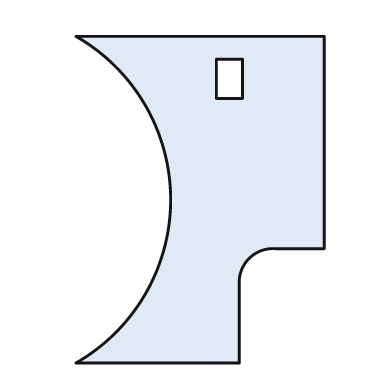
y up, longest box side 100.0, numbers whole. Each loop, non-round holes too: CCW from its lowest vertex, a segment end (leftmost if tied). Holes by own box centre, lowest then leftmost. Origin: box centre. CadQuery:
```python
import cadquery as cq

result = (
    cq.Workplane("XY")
    .moveTo(-38.0, -50.0)
    .lineTo(12.0, -50.0)
    .lineTo(12.0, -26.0)
    .threePointArc((15.0, -18.0), (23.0, -15.0))
    .lineTo(38.0, -15.0)
    .lineTo(38.0, 50.0)
    .lineTo(-38.0, 50.0)
    .threePointArc((-9.0, 0.0), (-38.0, -50.0))
    .close()
    .moveTo(5.0, 31.0)
    .lineTo(13.0, 31.0)
    .lineTo(13.0, 43.0)
    .lineTo(5.0, 43.0)
    .close()
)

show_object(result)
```